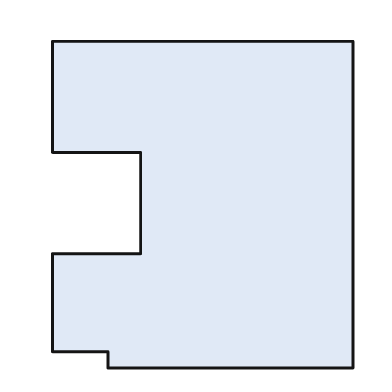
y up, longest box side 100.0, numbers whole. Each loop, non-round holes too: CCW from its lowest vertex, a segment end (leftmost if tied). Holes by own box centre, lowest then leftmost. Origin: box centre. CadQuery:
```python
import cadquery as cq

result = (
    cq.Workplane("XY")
    .moveTo(-29.0, -50.0)
    .lineTo(46.0, -50.0)
    .lineTo(46.0, 50.0)
    .lineTo(-46.0, 50.0)
    .lineTo(-46.0, 16.0)
    .lineTo(-19.0, 16.0)
    .lineTo(-19.0, -15.0)
    .lineTo(-46.0, -15.0)
    .lineTo(-46.0, -45.0)
    .lineTo(-29.0, -45.0)
    .close()
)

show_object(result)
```